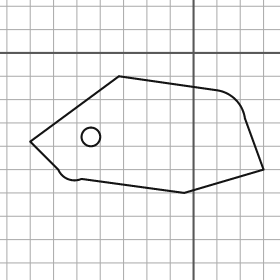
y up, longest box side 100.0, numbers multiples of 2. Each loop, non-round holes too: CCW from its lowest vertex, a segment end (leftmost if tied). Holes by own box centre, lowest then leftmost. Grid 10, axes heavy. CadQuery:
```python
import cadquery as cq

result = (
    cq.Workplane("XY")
    .moveTo(-4.0, -60.0)
    .lineTo(30.0, -50.0)
    .lineTo(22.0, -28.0)
    .threePointArc((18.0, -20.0), (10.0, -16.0))
    .lineTo(-32.0, -10.0)
    .lineTo(-70.0, -38.0)
    .lineTo(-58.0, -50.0)
    .threePointArc((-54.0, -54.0), (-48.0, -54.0))
    .close()
    .moveTo(-44.0, -36.0)
    .circle(4.0)
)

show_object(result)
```